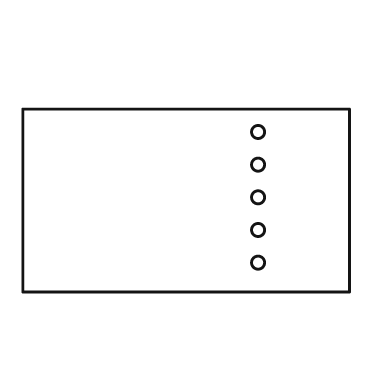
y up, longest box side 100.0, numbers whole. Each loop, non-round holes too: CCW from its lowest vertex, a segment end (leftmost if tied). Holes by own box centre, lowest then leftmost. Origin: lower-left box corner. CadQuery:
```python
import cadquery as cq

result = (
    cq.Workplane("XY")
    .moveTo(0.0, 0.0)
    .lineTo(100.0, 0.0)
    .lineTo(100.0, 56.0)
    .lineTo(0.0, 56.0)
    .close()
    .moveTo(72.0, 9.0)
    .circle(2.0)
    .moveTo(72.0, 19.0)
    .circle(2.0)
    .moveTo(72.0, 29.0)
    .circle(2.0)
    .moveTo(72.0, 39.0)
    .circle(2.0)
    .moveTo(72.0, 49.0)
    .circle(2.0)
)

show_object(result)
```